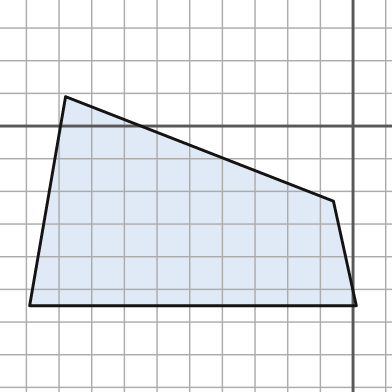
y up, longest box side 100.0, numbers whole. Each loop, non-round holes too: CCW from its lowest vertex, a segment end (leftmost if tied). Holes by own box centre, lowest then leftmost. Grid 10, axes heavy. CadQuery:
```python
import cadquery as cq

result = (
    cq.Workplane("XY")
    .moveTo(-99.0, -55.0)
    .lineTo(1.0, -55.0)
    .lineTo(-6.0, -23.0)
    .lineTo(-88.0, 9.0)
    .close()
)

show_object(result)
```